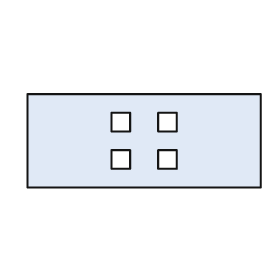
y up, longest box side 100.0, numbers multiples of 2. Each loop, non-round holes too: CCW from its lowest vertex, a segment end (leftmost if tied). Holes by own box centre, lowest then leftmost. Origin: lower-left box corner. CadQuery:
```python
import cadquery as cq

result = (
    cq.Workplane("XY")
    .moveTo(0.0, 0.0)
    .lineTo(100.0, 0.0)
    .lineTo(100.0, 40.0)
    .lineTo(0.0, 40.0)
    .close()
    .moveTo(36.0, 8.0)
    .lineTo(44.0, 8.0)
    .lineTo(44.0, 16.0)
    .lineTo(36.0, 16.0)
    .close()
    .moveTo(56.0, 8.0)
    .lineTo(64.0, 8.0)
    .lineTo(64.0, 16.0)
    .lineTo(56.0, 16.0)
    .close()
    .moveTo(36.0, 24.0)
    .lineTo(44.0, 24.0)
    .lineTo(44.0, 32.0)
    .lineTo(36.0, 32.0)
    .close()
    .moveTo(56.0, 24.0)
    .lineTo(64.0, 24.0)
    .lineTo(64.0, 32.0)
    .lineTo(56.0, 32.0)
    .close()
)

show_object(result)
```